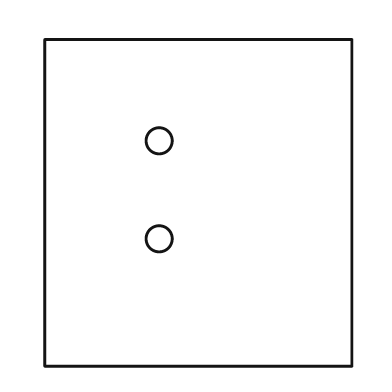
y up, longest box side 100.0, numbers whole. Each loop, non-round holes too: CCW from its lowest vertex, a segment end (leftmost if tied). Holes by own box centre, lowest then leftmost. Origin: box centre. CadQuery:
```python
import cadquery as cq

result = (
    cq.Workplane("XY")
    .moveTo(-47.0, -50.0)
    .lineTo(47.0, -50.0)
    .lineTo(47.0, 50.0)
    .lineTo(-47.0, 50.0)
    .close()
    .moveTo(-12.0, -11.0)
    .circle(4.0)
    .moveTo(-12.0, 19.0)
    .circle(4.0)
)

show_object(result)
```